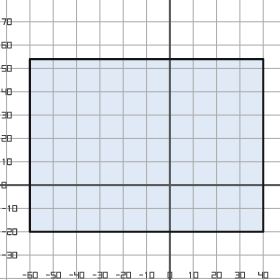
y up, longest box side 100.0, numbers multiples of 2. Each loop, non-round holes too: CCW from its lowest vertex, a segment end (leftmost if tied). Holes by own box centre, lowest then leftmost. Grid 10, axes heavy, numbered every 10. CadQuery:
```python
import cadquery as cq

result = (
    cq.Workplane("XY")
    .moveTo(-60.0, -20.0)
    .lineTo(40.0, -20.0)
    .lineTo(40.0, 54.0)
    .lineTo(-60.0, 54.0)
    .close()
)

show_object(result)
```